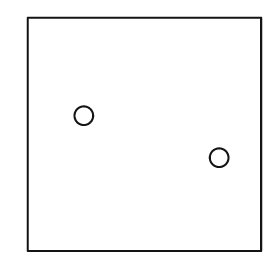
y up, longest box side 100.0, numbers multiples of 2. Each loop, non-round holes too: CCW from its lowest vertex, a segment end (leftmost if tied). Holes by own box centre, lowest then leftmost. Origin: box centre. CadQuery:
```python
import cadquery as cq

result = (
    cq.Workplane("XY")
    .moveTo(-50.0, -50.0)
    .lineTo(50.0, -50.0)
    .lineTo(50.0, 50.0)
    .lineTo(-50.0, 50.0)
    .close()
    .moveTo(32.0, -10.0)
    .circle(4.0)
    .moveTo(-26.0, 8.0)
    .circle(4.0)
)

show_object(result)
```